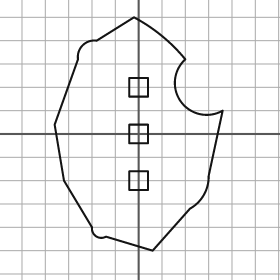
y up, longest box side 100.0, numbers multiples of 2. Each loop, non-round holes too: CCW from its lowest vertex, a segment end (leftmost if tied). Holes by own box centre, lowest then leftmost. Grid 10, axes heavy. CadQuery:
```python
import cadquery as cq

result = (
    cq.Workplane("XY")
    .moveTo(6.0, -50.0)
    .lineTo(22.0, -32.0)
    .threePointArc((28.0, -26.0), (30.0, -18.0))
    .lineTo(36.0, 10.0)
    .threePointArc((18.0, 14.0), (20.0, 32.0))
    .threePointArc((10.0, 42.0), (-2.0, 50.0))
    .lineTo(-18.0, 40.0)
    .threePointArc((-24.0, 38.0), (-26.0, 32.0))
    .lineTo(-36.0, 4.0)
    .lineTo(-32.0, -20.0)
    .lineTo(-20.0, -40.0)
    .threePointArc((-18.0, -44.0), (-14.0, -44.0))
    .close()
    .moveTo(-4.0, -24.0)
    .lineTo(4.0, -24.0)
    .lineTo(4.0, -16.0)
    .lineTo(-4.0, -16.0)
    .close()
    .moveTo(-4.0, -4.0)
    .lineTo(4.0, -4.0)
    .lineTo(4.0, 4.0)
    .lineTo(-4.0, 4.0)
    .close()
    .moveTo(-4.0, 16.0)
    .lineTo(4.0, 16.0)
    .lineTo(4.0, 24.0)
    .lineTo(-4.0, 24.0)
    .close()
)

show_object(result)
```